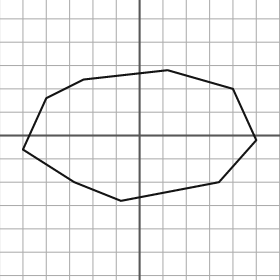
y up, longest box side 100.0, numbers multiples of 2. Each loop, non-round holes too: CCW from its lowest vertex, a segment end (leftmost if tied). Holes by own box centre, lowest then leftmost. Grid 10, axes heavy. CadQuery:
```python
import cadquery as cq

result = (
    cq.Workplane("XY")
    .moveTo(-8.0, -28.0)
    .lineTo(34.0, -20.0)
    .lineTo(50.0, -2.0)
    .lineTo(40.0, 20.0)
    .lineTo(12.0, 28.0)
    .lineTo(-24.0, 24.0)
    .lineTo(-40.0, 16.0)
    .lineTo(-50.0, -6.0)
    .lineTo(-28.0, -20.0)
    .close()
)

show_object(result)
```